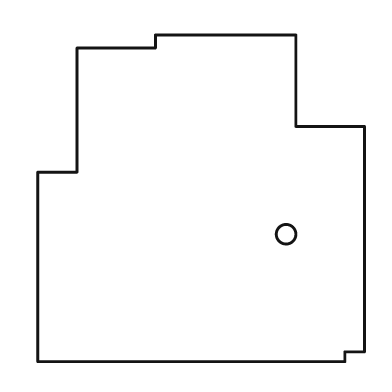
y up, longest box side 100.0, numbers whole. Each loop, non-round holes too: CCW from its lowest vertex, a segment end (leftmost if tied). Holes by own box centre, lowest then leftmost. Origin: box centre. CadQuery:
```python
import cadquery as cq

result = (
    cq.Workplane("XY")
    .moveTo(-50.0, -50.0)
    .lineTo(44.0, -50.0)
    .lineTo(44.0, -47.0)
    .lineTo(50.0, -47.0)
    .lineTo(50.0, 22.0)
    .lineTo(29.0, 22.0)
    .lineTo(29.0, 50.0)
    .lineTo(-14.0, 50.0)
    .lineTo(-14.0, 46.0)
    .lineTo(-38.0, 46.0)
    .lineTo(-38.0, 8.0)
    .lineTo(-50.0, 8.0)
    .close()
    .moveTo(26.0, -11.0)
    .circle(3.0)
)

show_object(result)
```